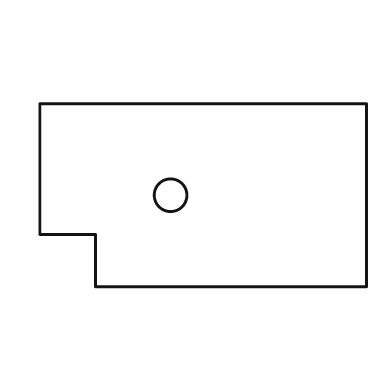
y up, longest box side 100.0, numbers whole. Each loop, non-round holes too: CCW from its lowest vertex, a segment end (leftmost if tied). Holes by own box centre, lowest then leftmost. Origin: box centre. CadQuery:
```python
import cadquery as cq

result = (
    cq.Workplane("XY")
    .moveTo(-33.0, -28.0)
    .lineTo(50.0, -28.0)
    .lineTo(50.0, 28.0)
    .lineTo(-50.0, 28.0)
    .lineTo(-50.0, -12.0)
    .lineTo(-33.0, -12.0)
    .close()
    .moveTo(-10.0, 0.0)
    .circle(5.0)
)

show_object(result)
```